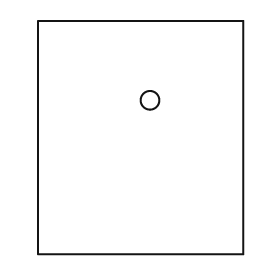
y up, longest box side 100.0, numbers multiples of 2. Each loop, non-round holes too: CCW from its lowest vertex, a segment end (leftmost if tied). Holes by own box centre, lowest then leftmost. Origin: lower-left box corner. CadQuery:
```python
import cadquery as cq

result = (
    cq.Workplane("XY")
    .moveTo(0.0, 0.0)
    .lineTo(88.0, 0.0)
    .lineTo(88.0, 100.0)
    .lineTo(0.0, 100.0)
    .close()
    .moveTo(48.0, 66.0)
    .circle(4.0)
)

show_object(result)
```